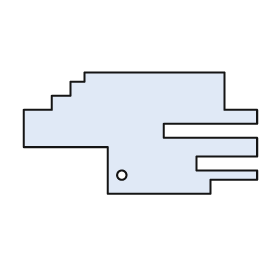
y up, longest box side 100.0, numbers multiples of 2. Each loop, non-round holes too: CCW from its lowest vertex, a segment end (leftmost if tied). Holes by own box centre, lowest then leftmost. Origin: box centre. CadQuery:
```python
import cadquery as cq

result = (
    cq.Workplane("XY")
    .moveTo(-14.0, -26.0)
    .lineTo(30.0, -26.0)
    .lineTo(30.0, -20.0)
    .lineTo(50.0, -20.0)
    .lineTo(50.0, -16.0)
    .lineTo(24.0, -16.0)
    .lineTo(24.0, -10.0)
    .lineTo(50.0, -10.0)
    .lineTo(50.0, -2.0)
    .lineTo(10.0, -2.0)
    .lineTo(10.0, 4.0)
    .lineTo(50.0, 4.0)
    .lineTo(50.0, 10.0)
    .lineTo(36.0, 10.0)
    .lineTo(36.0, 26.0)
    .lineTo(-24.0, 26.0)
    .lineTo(-24.0, 22.0)
    .lineTo(-30.0, 22.0)
    .lineTo(-30.0, 16.0)
    .lineTo(-38.0, 16.0)
    .lineTo(-38.0, 10.0)
    .lineTo(-50.0, 10.0)
    .lineTo(-50.0, -6.0)
    .lineTo(-14.0, -6.0)
    .close()
    .moveTo(-8.0, -18.0)
    .circle(2.0)
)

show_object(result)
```